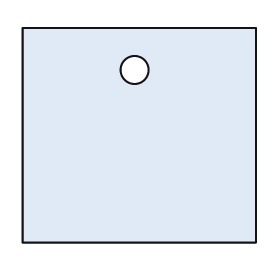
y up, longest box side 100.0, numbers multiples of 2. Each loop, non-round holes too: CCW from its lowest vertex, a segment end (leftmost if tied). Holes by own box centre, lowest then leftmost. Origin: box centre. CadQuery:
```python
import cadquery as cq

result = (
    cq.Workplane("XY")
    .moveTo(-50.0, -46.0)
    .lineTo(50.0, -46.0)
    .lineTo(50.0, 46.0)
    .lineTo(-50.0, 46.0)
    .close()
    .moveTo(-2.0, 28.0)
    .circle(6.0)
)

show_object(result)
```